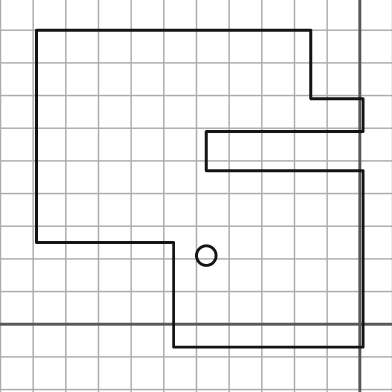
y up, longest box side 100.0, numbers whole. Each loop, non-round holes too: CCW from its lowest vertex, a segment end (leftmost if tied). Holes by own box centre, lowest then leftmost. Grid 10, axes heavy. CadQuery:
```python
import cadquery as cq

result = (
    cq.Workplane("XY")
    .moveTo(-57.0, -7.0)
    .lineTo(1.0, -7.0)
    .lineTo(1.0, 47.0)
    .lineTo(-47.0, 47.0)
    .lineTo(-47.0, 59.0)
    .lineTo(1.0, 59.0)
    .lineTo(1.0, 69.0)
    .lineTo(-15.0, 69.0)
    .lineTo(-15.0, 90.0)
    .lineTo(-99.0, 90.0)
    .lineTo(-99.0, 25.0)
    .lineTo(-57.0, 25.0)
    .close()
    .moveTo(-47.0, 21.0)
    .circle(3.0)
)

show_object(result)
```